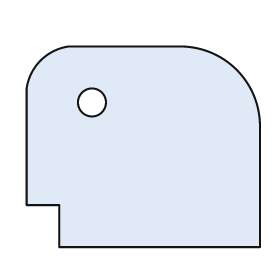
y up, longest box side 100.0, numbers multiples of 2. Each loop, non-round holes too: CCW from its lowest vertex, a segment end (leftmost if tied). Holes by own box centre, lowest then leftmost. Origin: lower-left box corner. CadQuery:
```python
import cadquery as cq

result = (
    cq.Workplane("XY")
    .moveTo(14.0, 0.0)
    .lineTo(100.0, 0.0)
    .lineTo(100.0, 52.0)
    .threePointArc((90.0, 76.0), (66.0, 86.0))
    .lineTo(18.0, 86.0)
    .threePointArc((6.0, 80.0), (0.0, 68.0))
    .lineTo(0.0, 18.0)
    .lineTo(14.0, 18.0)
    .close()
    .moveTo(28.0, 62.0)
    .circle(6.0)
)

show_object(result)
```